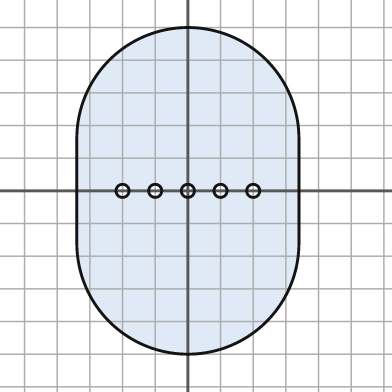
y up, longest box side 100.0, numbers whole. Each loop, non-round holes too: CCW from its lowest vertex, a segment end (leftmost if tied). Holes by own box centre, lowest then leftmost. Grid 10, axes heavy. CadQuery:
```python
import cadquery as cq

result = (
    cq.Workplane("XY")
    .moveTo(-34.0, -16.0)
    .threePointArc((0.0, -50.0), (34.0, -16.0))
    .lineTo(34.0, 16.0)
    .threePointArc((0.0, 50.0), (-34.0, 16.0))
    .close()
    .moveTo(-20.0, 0.0)
    .circle(2.0)
    .moveTo(-10.0, 0.0)
    .circle(2.0)
    .moveTo(0.0, 0.0)
    .circle(2.0)
    .moveTo(10.0, 0.0)
    .circle(2.0)
    .moveTo(20.0, 0.0)
    .circle(2.0)
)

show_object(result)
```